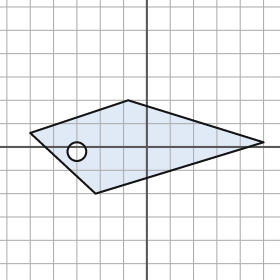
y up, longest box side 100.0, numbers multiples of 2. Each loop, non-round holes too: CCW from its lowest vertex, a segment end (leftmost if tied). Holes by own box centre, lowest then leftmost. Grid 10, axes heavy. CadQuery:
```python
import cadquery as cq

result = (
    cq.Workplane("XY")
    .moveTo(-22.0, -20.0)
    .lineTo(50.0, 2.0)
    .lineTo(-8.0, 20.0)
    .lineTo(-50.0, 6.0)
    .close()
    .moveTo(-30.0, -2.0)
    .circle(4.0)
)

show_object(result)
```